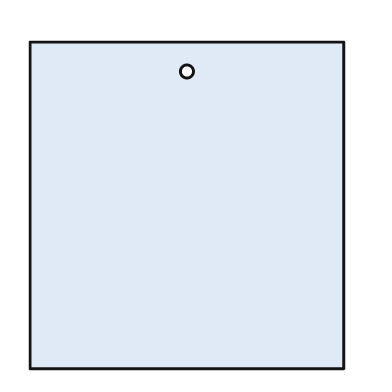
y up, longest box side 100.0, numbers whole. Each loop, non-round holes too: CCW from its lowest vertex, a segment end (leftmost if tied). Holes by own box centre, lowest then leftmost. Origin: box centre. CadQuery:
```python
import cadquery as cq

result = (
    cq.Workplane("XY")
    .moveTo(-48.0, -50.0)
    .lineTo(48.0, -50.0)
    .lineTo(48.0, 50.0)
    .lineTo(-48.0, 50.0)
    .close()
    .moveTo(0.0, 41.0)
    .circle(2.0)
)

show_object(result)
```